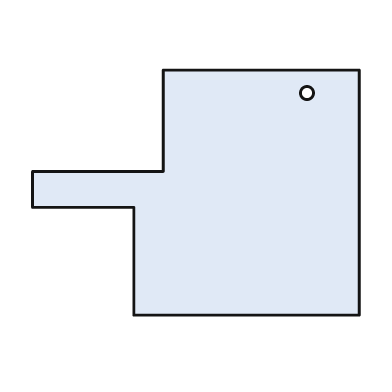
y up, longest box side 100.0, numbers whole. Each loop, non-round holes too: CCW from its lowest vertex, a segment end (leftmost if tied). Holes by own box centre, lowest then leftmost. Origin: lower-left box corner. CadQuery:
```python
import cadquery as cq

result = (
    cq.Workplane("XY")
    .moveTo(31.0, 0.0)
    .lineTo(100.0, 0.0)
    .lineTo(100.0, 75.0)
    .lineTo(40.0, 75.0)
    .lineTo(40.0, 44.0)
    .lineTo(0.0, 44.0)
    .lineTo(0.0, 33.0)
    .lineTo(31.0, 33.0)
    .close()
    .moveTo(84.0, 68.0)
    .circle(2.0)
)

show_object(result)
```